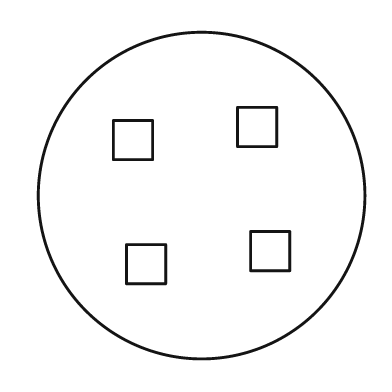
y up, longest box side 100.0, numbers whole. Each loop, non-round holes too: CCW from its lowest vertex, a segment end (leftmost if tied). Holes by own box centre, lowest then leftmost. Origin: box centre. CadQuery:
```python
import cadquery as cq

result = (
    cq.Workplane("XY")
    .moveTo(0.0, 0.0)
    .circle(50.0)
    .moveTo(-23.0, -27.0)
    .lineTo(-11.0, -27.0)
    .lineTo(-11.0, -15.0)
    .lineTo(-23.0, -15.0)
    .close()
    .moveTo(15.0, -23.0)
    .lineTo(27.0, -23.0)
    .lineTo(27.0, -11.0)
    .lineTo(15.0, -11.0)
    .close()
    .moveTo(-27.0, 11.0)
    .lineTo(-15.0, 11.0)
    .lineTo(-15.0, 23.0)
    .lineTo(-27.0, 23.0)
    .close()
    .moveTo(11.0, 15.0)
    .lineTo(23.0, 15.0)
    .lineTo(23.0, 27.0)
    .lineTo(11.0, 27.0)
    .close()
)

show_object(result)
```